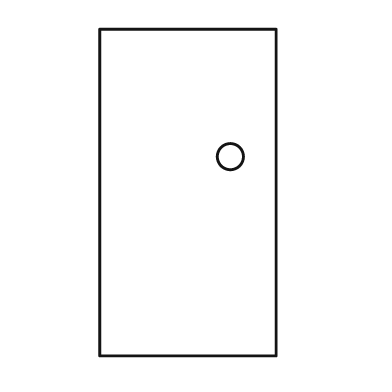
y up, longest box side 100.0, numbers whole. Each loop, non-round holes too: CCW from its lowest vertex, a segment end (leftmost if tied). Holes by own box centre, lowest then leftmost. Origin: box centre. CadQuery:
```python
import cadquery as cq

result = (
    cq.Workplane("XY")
    .moveTo(-27.0, -50.0)
    .lineTo(27.0, -50.0)
    .lineTo(27.0, 50.0)
    .lineTo(-27.0, 50.0)
    .close()
    .moveTo(13.0, 11.0)
    .circle(4.0)
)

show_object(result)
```